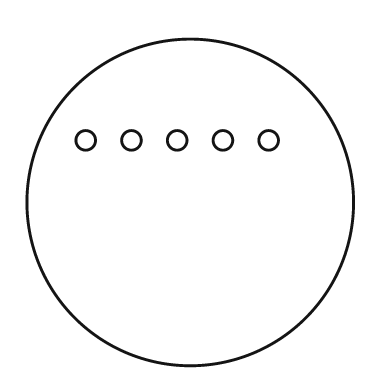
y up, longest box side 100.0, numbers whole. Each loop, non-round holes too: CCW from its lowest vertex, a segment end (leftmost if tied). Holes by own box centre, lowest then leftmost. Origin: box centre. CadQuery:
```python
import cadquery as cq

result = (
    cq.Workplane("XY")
    .moveTo(0.0, 0.0)
    .circle(50.0)
    .moveTo(-32.0, 19.0)
    .circle(3.0)
    .moveTo(-18.0, 19.0)
    .circle(3.0)
    .moveTo(-4.0, 19.0)
    .circle(3.0)
    .moveTo(10.0, 19.0)
    .circle(3.0)
    .moveTo(24.0, 19.0)
    .circle(3.0)
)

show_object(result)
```